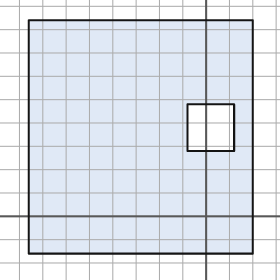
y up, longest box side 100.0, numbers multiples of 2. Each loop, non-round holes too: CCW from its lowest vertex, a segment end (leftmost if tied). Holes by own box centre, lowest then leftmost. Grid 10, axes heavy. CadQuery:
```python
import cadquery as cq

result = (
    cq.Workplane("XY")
    .moveTo(-76.0, -16.0)
    .lineTo(20.0, -16.0)
    .lineTo(20.0, 84.0)
    .lineTo(-76.0, 84.0)
    .close()
    .moveTo(-8.0, 28.0)
    .lineTo(12.0, 28.0)
    .lineTo(12.0, 48.0)
    .lineTo(-8.0, 48.0)
    .close()
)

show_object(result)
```